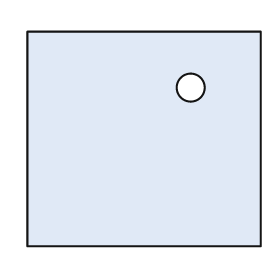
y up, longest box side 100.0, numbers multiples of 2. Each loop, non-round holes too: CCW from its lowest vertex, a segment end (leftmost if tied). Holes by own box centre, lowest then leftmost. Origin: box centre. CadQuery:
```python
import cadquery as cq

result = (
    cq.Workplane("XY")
    .moveTo(-50.0, -46.0)
    .lineTo(50.0, -46.0)
    .lineTo(50.0, 46.0)
    .lineTo(-50.0, 46.0)
    .close()
    .moveTo(20.0, 22.0)
    .circle(6.0)
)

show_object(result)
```